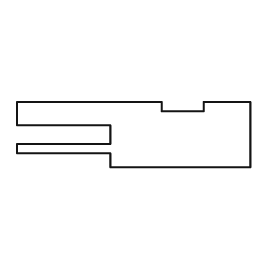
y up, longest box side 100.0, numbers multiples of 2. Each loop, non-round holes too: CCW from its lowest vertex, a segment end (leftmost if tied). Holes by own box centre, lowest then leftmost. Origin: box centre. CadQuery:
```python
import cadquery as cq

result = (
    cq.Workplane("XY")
    .moveTo(-10.0, -14.0)
    .lineTo(50.0, -14.0)
    .lineTo(50.0, 14.0)
    .lineTo(30.0, 14.0)
    .lineTo(30.0, 10.0)
    .lineTo(12.0, 10.0)
    .lineTo(12.0, 14.0)
    .lineTo(-50.0, 14.0)
    .lineTo(-50.0, 4.0)
    .lineTo(-10.0, 4.0)
    .lineTo(-10.0, -4.0)
    .lineTo(-50.0, -4.0)
    .lineTo(-50.0, -8.0)
    .lineTo(-10.0, -8.0)
    .close()
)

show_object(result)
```